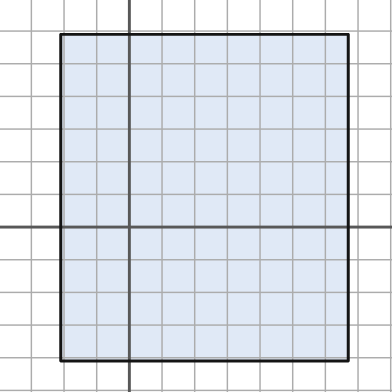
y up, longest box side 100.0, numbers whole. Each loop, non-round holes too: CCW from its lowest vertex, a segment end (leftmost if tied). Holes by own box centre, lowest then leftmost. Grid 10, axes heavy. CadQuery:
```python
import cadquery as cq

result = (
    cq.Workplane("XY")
    .moveTo(-21.0, -41.0)
    .lineTo(67.0, -41.0)
    .lineTo(67.0, 59.0)
    .lineTo(-21.0, 59.0)
    .close()
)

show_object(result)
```